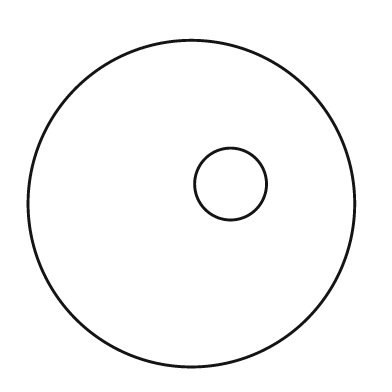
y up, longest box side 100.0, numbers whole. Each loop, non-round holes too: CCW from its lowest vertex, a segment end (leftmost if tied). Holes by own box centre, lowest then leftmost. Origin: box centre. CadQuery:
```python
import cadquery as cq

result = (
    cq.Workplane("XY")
    .moveTo(0.0, 0.0)
    .circle(50.0)
    .moveTo(12.0, 6.0)
    .circle(11.0)
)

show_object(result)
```